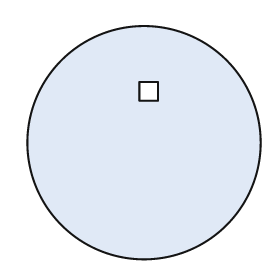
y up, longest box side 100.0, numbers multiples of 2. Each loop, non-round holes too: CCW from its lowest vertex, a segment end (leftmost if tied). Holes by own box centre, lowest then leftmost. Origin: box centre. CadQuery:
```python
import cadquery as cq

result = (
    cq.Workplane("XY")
    .moveTo(0.0, 0.0)
    .circle(50.0)
    .moveTo(-2.0, 18.0)
    .lineTo(6.0, 18.0)
    .lineTo(6.0, 26.0)
    .lineTo(-2.0, 26.0)
    .close()
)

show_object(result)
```